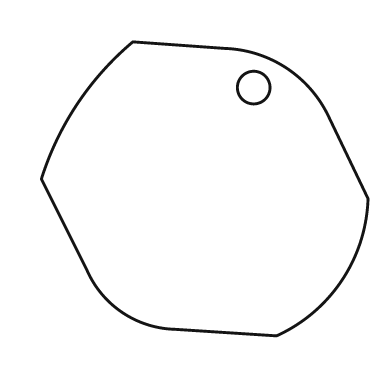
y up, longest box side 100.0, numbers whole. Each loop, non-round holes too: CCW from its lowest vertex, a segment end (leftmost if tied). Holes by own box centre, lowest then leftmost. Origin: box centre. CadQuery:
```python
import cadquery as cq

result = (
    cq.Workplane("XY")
    .moveTo(22.0, -45.0)
    .threePointArc((42.0, -28.0), (50.0, -3.0))
    .lineTo(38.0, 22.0)
    .threePointArc((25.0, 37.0), (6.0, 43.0))
    .lineTo(-22.0, 45.0)
    .threePointArc((-39.0, 26.0), (-50.0, 3.0))
    .lineTo(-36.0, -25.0)
    .threePointArc((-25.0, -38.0), (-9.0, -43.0))
    .close()
    .moveTo(15.0, 31.0)
    .circle(5.0)
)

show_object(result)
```